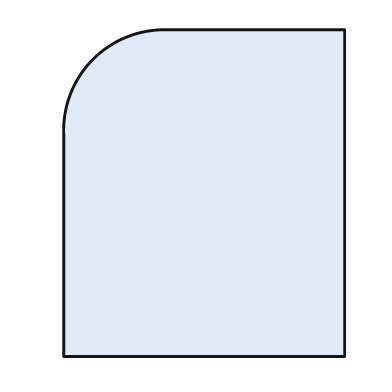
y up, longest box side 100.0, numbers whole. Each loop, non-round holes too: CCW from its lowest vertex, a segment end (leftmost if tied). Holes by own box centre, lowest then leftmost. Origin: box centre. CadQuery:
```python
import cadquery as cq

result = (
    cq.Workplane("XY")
    .moveTo(-43.0, -50.0)
    .lineTo(43.0, -50.0)
    .lineTo(43.0, 50.0)
    .lineTo(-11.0, 50.0)
    .threePointArc((-34.0, 41.0), (-43.0, 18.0))
    .close()
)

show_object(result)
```